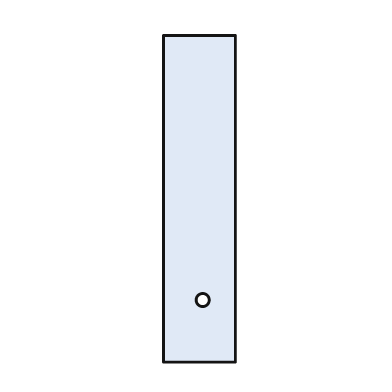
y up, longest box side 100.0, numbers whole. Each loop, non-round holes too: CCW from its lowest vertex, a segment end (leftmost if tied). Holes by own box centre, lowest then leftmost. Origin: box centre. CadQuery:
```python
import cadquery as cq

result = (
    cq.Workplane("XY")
    .moveTo(-11.0, -50.0)
    .lineTo(11.0, -50.0)
    .lineTo(11.0, 50.0)
    .lineTo(-11.0, 50.0)
    .close()
    .moveTo(1.0, -31.0)
    .circle(2.0)
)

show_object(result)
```